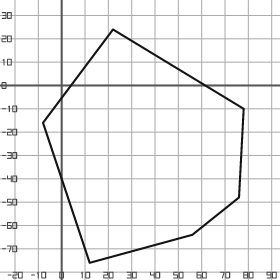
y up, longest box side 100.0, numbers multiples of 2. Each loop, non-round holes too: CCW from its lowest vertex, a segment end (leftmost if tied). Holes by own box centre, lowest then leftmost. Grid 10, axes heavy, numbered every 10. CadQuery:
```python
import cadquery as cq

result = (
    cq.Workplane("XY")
    .moveTo(12.0, -76.0)
    .lineTo(56.0, -64.0)
    .lineTo(76.0, -48.0)
    .lineTo(78.0, -10.0)
    .lineTo(22.0, 24.0)
    .lineTo(-8.0, -16.0)
    .close()
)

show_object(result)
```